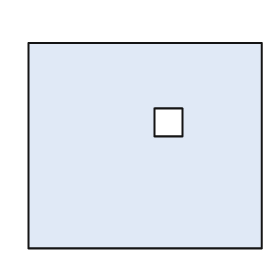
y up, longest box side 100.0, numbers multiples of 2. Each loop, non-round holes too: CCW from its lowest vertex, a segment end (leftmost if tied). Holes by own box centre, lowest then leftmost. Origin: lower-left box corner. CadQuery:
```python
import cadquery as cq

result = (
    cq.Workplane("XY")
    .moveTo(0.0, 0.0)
    .lineTo(100.0, 0.0)
    .lineTo(100.0, 88.0)
    .lineTo(0.0, 88.0)
    .close()
    .moveTo(54.0, 48.0)
    .lineTo(66.0, 48.0)
    .lineTo(66.0, 60.0)
    .lineTo(54.0, 60.0)
    .close()
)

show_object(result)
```